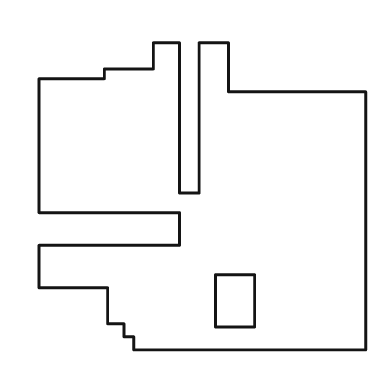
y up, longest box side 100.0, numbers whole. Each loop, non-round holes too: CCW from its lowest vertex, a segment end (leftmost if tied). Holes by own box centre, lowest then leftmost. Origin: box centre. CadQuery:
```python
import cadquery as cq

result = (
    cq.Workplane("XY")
    .moveTo(-21.0, -47.0)
    .lineTo(50.0, -47.0)
    .lineTo(50.0, 32.0)
    .lineTo(8.0, 32.0)
    .lineTo(8.0, 47.0)
    .lineTo(-1.0, 47.0)
    .lineTo(-1.0, 1.0)
    .lineTo(-7.0, 1.0)
    .lineTo(-7.0, 47.0)
    .lineTo(-15.0, 47.0)
    .lineTo(-15.0, 39.0)
    .lineTo(-30.0, 39.0)
    .lineTo(-30.0, 36.0)
    .lineTo(-50.0, 36.0)
    .lineTo(-50.0, -5.0)
    .lineTo(-7.0, -5.0)
    .lineTo(-7.0, -15.0)
    .lineTo(-50.0, -15.0)
    .lineTo(-50.0, -28.0)
    .lineTo(-29.0, -28.0)
    .lineTo(-29.0, -39.0)
    .lineTo(-24.0, -39.0)
    .lineTo(-24.0, -43.0)
    .lineTo(-21.0, -43.0)
    .close()
    .moveTo(4.0, -40.0)
    .lineTo(16.0, -40.0)
    .lineTo(16.0, -24.0)
    .lineTo(4.0, -24.0)
    .close()
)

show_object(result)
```